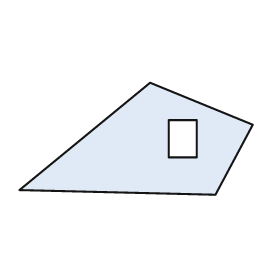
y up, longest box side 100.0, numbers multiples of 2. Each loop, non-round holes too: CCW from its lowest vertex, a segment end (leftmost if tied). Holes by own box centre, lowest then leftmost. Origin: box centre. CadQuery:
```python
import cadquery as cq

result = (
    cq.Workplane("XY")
    .moveTo(34.0, -24.0)
    .lineTo(50.0, 6.0)
    .lineTo(6.0, 24.0)
    .lineTo(-50.0, -22.0)
    .close()
    .moveTo(14.0, -8.0)
    .lineTo(26.0, -8.0)
    .lineTo(26.0, 8.0)
    .lineTo(14.0, 8.0)
    .close()
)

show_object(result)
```